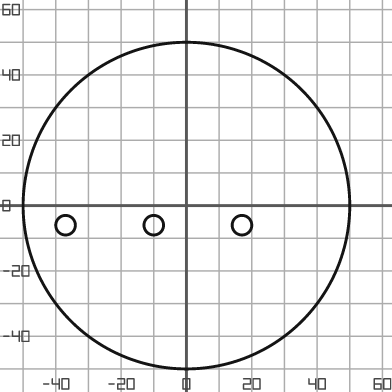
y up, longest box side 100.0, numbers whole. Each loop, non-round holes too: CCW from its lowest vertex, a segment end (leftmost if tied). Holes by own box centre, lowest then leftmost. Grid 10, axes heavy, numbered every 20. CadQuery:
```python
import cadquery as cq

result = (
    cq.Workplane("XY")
    .moveTo(0.0, 0.0)
    .circle(50.0)
    .moveTo(-37.0, -6.0)
    .circle(3.0)
    .moveTo(-10.0, -6.0)
    .circle(3.0)
    .moveTo(17.0, -6.0)
    .circle(3.0)
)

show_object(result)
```